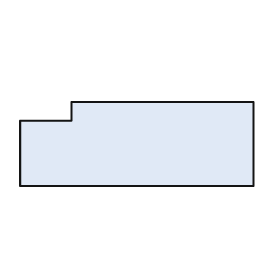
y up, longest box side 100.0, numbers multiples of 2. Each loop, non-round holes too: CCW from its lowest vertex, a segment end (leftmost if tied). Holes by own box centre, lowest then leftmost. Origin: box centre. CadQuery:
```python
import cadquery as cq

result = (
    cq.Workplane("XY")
    .moveTo(-50.0, -18.0)
    .lineTo(50.0, -18.0)
    .lineTo(50.0, 18.0)
    .lineTo(-28.0, 18.0)
    .lineTo(-28.0, 10.0)
    .lineTo(-50.0, 10.0)
    .close()
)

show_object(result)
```